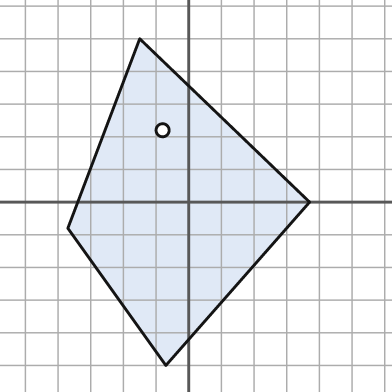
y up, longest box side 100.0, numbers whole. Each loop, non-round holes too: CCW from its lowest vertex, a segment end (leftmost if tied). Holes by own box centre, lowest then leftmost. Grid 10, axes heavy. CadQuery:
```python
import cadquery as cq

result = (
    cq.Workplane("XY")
    .moveTo(-7.0, -50.0)
    .lineTo(37.0, 0.0)
    .lineTo(-15.0, 50.0)
    .lineTo(-37.0, -8.0)
    .close()
    .moveTo(-8.0, 22.0)
    .circle(2.0)
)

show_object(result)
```